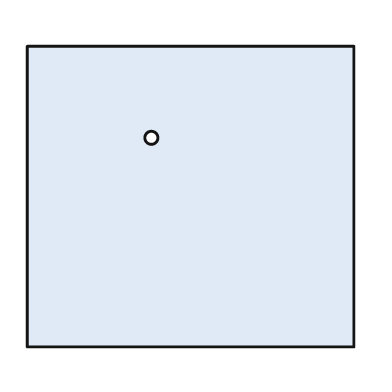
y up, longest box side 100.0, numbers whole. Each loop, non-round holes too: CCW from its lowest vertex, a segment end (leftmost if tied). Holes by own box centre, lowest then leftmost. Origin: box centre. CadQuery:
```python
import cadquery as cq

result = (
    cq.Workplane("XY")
    .moveTo(-50.0, -46.0)
    .lineTo(50.0, -46.0)
    .lineTo(50.0, 46.0)
    .lineTo(-50.0, 46.0)
    .close()
    .moveTo(-12.0, 18.0)
    .circle(2.0)
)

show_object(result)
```